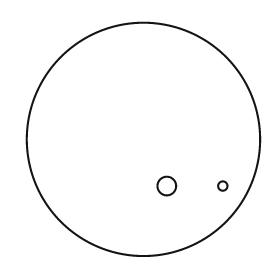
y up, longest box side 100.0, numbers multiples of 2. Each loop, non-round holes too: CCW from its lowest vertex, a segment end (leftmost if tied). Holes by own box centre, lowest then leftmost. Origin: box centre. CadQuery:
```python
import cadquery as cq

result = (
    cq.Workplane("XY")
    .moveTo(0.0, 0.0)
    .circle(50.0)
    .moveTo(10.0, -20.0)
    .circle(4.0)
    .moveTo(34.0, -20.0)
    .circle(2.0)
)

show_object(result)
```